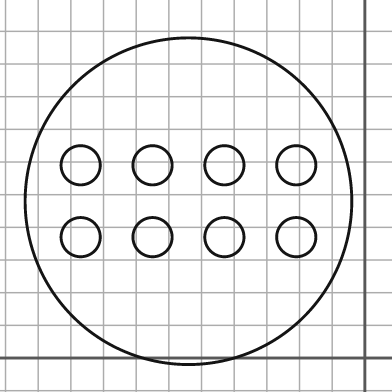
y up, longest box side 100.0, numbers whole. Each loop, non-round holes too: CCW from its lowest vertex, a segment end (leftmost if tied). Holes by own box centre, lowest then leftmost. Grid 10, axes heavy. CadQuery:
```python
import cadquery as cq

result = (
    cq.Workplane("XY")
    .moveTo(-54.0, 48.0)
    .circle(50.0)
    .moveTo(-87.0, 37.0)
    .circle(6.0)
    .moveTo(-65.0, 37.0)
    .circle(6.0)
    .moveTo(-43.0, 37.0)
    .circle(6.0)
    .moveTo(-21.0, 37.0)
    .circle(6.0)
    .moveTo(-87.0, 59.0)
    .circle(6.0)
    .moveTo(-65.0, 59.0)
    .circle(6.0)
    .moveTo(-43.0, 59.0)
    .circle(6.0)
    .moveTo(-21.0, 59.0)
    .circle(6.0)
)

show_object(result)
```